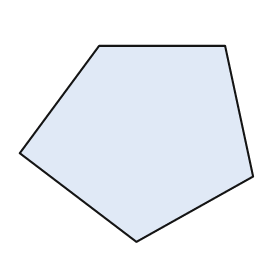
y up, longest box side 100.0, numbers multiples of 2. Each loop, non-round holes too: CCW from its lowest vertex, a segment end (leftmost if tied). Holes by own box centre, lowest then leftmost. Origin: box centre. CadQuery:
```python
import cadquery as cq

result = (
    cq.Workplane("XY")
    .moveTo(0.0, -42.0)
    .lineTo(50.0, -14.0)
    .lineTo(38.0, 42.0)
    .lineTo(-16.0, 42.0)
    .lineTo(-50.0, -4.0)
    .close()
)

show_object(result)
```